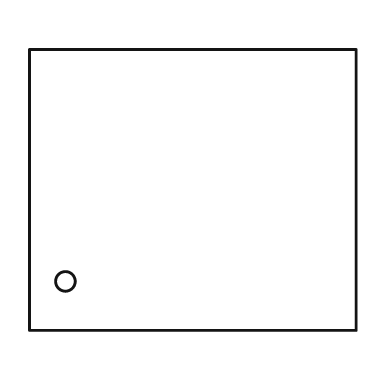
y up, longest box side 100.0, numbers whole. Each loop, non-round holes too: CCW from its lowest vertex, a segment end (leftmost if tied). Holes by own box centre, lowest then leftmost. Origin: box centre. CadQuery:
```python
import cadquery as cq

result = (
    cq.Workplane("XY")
    .moveTo(-50.0, -43.0)
    .lineTo(50.0, -43.0)
    .lineTo(50.0, 43.0)
    .lineTo(-50.0, 43.0)
    .close()
    .moveTo(-39.0, -28.0)
    .circle(3.0)
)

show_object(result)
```